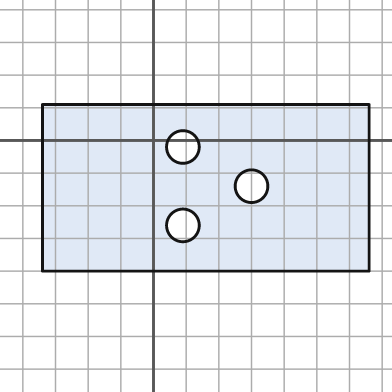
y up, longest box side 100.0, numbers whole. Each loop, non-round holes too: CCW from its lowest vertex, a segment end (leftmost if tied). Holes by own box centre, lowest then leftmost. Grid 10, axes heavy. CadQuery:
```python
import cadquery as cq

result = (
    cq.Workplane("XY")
    .moveTo(-34.0, -40.0)
    .lineTo(66.0, -40.0)
    .lineTo(66.0, 11.0)
    .lineTo(-34.0, 11.0)
    .close()
    .moveTo(9.0, -26.0)
    .circle(5.0)
    .moveTo(30.0, -14.0)
    .circle(5.0)
    .moveTo(9.0, -2.0)
    .circle(5.0)
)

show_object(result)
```